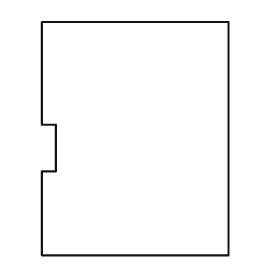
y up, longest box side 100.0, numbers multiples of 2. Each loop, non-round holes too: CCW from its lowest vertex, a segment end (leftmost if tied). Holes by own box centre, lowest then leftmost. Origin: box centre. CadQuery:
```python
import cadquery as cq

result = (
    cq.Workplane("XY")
    .moveTo(-40.0, -50.0)
    .lineTo(40.0, -50.0)
    .lineTo(40.0, 50.0)
    .lineTo(-40.0, 50.0)
    .lineTo(-40.0, 6.0)
    .lineTo(-34.0, 6.0)
    .lineTo(-34.0, -14.0)
    .lineTo(-40.0, -14.0)
    .close()
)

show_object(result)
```